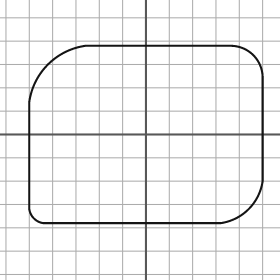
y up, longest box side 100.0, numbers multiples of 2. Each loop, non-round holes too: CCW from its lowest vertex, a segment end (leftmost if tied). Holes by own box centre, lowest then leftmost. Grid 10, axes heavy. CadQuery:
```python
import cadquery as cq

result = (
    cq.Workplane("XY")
    .moveTo(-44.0, -38.0)
    .lineTo(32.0, -38.0)
    .threePointArc((44.0, -32.0), (50.0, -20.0))
    .lineTo(50.0, 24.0)
    .threePointArc((46.0, 34.0), (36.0, 38.0))
    .lineTo(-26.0, 38.0)
    .threePointArc((-42.0, 30.0), (-50.0, 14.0))
    .lineTo(-50.0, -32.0)
    .threePointArc((-48.0, -36.0), (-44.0, -38.0))
    .close()
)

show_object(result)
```